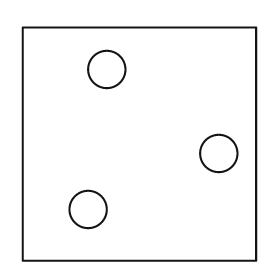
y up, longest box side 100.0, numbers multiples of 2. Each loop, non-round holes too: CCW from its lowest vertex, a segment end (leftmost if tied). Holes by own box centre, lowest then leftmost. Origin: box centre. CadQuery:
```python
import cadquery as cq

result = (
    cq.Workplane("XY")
    .moveTo(-50.0, -50.0)
    .lineTo(50.0, -50.0)
    .lineTo(50.0, 50.0)
    .lineTo(-50.0, 50.0)
    .close()
    .moveTo(-22.0, -28.0)
    .circle(8.0)
    .moveTo(34.0, -4.0)
    .circle(8.0)
    .moveTo(-14.0, 32.0)
    .circle(8.0)
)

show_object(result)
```